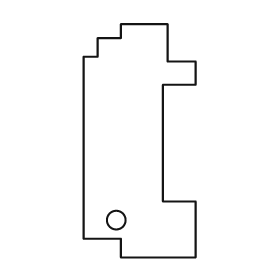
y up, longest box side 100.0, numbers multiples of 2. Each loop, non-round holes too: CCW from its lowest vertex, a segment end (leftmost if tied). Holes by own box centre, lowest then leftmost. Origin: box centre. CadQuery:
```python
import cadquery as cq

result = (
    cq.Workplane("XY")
    .moveTo(-8.0, -50.0)
    .lineTo(24.0, -50.0)
    .lineTo(24.0, -26.0)
    .lineTo(10.0, -26.0)
    .lineTo(10.0, 24.0)
    .lineTo(24.0, 24.0)
    .lineTo(24.0, 34.0)
    .lineTo(12.0, 34.0)
    .lineTo(12.0, 50.0)
    .lineTo(-8.0, 50.0)
    .lineTo(-8.0, 44.0)
    .lineTo(-18.0, 44.0)
    .lineTo(-18.0, 36.0)
    .lineTo(-24.0, 36.0)
    .lineTo(-24.0, -42.0)
    .lineTo(-8.0, -42.0)
    .close()
    .moveTo(-10.0, -34.0)
    .circle(4.0)
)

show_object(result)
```